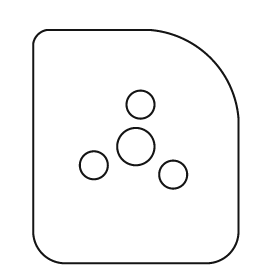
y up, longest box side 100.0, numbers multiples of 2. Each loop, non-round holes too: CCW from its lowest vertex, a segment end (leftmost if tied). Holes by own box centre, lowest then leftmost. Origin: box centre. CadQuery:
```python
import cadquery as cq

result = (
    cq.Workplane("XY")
    .moveTo(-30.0, -50.0)
    .lineTo(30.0, -50.0)
    .threePointArc((40.0, -46.0), (44.0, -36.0))
    .lineTo(44.0, 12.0)
    .threePointArc((32.0, 38.0), (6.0, 50.0))
    .lineTo(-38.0, 50.0)
    .threePointArc((-42.0, 48.0), (-44.0, 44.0))
    .lineTo(-44.0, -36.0)
    .threePointArc((-40.0, -46.0), (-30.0, -50.0))
    .close()
    .moveTo(16.0, -12.0)
    .circle(6.0)
    .moveTo(-18.0, -8.0)
    .circle(6.0)
    .moveTo(0.0, 0.0)
    .circle(8.0)
    .moveTo(2.0, 18.0)
    .circle(6.0)
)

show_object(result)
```